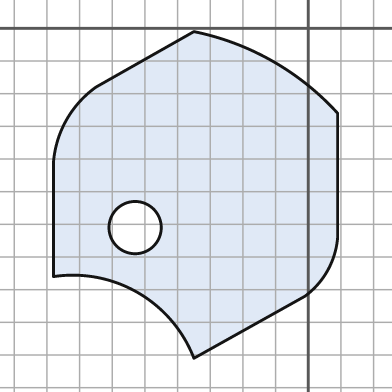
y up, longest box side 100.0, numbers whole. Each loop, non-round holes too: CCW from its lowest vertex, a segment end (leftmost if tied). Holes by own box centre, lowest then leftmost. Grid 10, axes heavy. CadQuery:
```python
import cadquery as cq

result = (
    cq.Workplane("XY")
    .moveTo(-35.0, -101.0)
    .lineTo(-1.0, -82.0)
    .threePointArc((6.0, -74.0), (9.0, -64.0))
    .lineTo(9.0, -26.0)
    .threePointArc((-11.0, -10.0), (-35.0, -1.0))
    .lineTo(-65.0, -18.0)
    .threePointArc((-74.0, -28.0), (-78.0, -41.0))
    .lineTo(-78.0, -76.0)
    .threePointArc((-52.0, -81.0), (-35.0, -101.0))
    .close()
    .moveTo(-53.0, -61.0)
    .circle(8.0)
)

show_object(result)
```